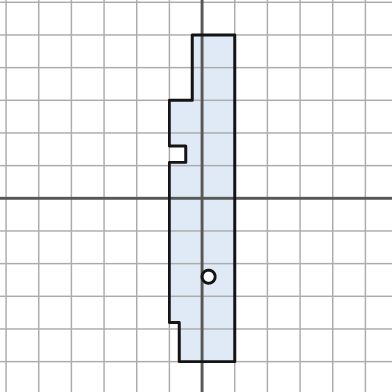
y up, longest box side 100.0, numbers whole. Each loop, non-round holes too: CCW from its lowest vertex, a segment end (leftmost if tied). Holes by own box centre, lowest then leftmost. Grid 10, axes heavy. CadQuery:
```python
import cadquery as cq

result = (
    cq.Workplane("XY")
    .moveTo(-7.0, -50.0)
    .lineTo(10.0, -50.0)
    .lineTo(10.0, 50.0)
    .lineTo(-3.0, 50.0)
    .lineTo(-3.0, 30.0)
    .lineTo(-10.0, 30.0)
    .lineTo(-10.0, 16.0)
    .lineTo(-5.0, 16.0)
    .lineTo(-5.0, 11.0)
    .lineTo(-10.0, 11.0)
    .lineTo(-10.0, -38.0)
    .lineTo(-7.0, -38.0)
    .close()
    .moveTo(2.0, -24.0)
    .circle(2.0)
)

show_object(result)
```